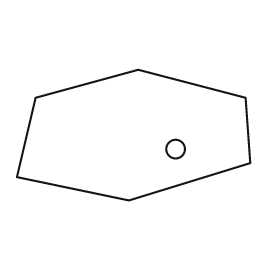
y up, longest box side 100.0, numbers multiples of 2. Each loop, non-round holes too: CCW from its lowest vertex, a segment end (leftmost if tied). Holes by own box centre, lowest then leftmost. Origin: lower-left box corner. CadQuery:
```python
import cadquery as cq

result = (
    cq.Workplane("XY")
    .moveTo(48.0, 0.0)
    .lineTo(100.0, 16.0)
    .lineTo(98.0, 44.0)
    .lineTo(52.0, 56.0)
    .lineTo(8.0, 44.0)
    .lineTo(0.0, 10.0)
    .close()
    .moveTo(68.0, 22.0)
    .circle(4.0)
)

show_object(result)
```